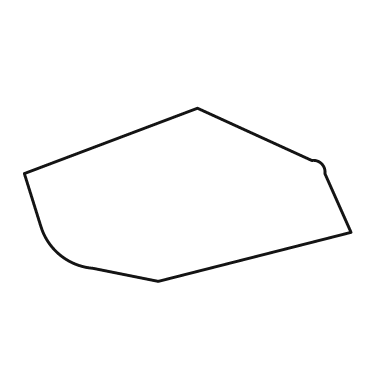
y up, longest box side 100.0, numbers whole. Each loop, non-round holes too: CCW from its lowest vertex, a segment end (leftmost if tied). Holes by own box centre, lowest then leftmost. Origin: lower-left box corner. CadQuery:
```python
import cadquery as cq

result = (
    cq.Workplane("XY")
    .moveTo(41.0, 0.0)
    .lineTo(100.0, 15.0)
    .lineTo(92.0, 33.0)
    .threePointArc((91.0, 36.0), (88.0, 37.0))
    .lineTo(53.0, 53.0)
    .lineTo(0.0, 33.0)
    .lineTo(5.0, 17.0)
    .threePointArc((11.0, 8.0), (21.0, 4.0))
    .close()
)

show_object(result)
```